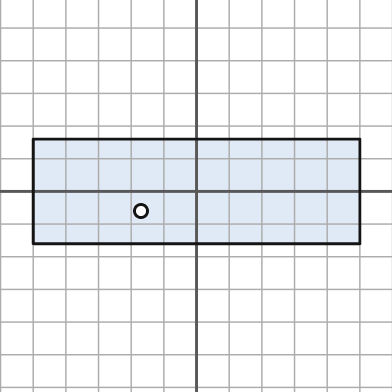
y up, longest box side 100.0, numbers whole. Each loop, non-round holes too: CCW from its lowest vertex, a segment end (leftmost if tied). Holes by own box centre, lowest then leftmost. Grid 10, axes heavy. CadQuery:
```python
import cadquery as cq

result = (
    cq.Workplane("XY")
    .moveTo(-50.0, -16.0)
    .lineTo(50.0, -16.0)
    .lineTo(50.0, 16.0)
    .lineTo(-50.0, 16.0)
    .close()
    .moveTo(-17.0, -6.0)
    .circle(2.0)
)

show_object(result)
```